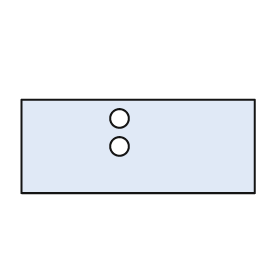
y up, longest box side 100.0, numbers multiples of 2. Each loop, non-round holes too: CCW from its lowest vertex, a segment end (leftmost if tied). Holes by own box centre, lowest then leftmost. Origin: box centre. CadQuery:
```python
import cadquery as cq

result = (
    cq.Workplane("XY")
    .moveTo(-50.0, -20.0)
    .lineTo(50.0, -20.0)
    .lineTo(50.0, 20.0)
    .lineTo(-50.0, 20.0)
    .close()
    .moveTo(-8.0, 0.0)
    .circle(4.0)
    .moveTo(-8.0, 12.0)
    .circle(4.0)
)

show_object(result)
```